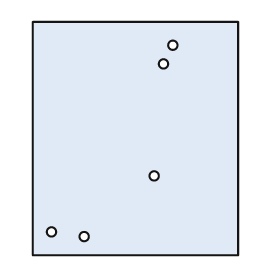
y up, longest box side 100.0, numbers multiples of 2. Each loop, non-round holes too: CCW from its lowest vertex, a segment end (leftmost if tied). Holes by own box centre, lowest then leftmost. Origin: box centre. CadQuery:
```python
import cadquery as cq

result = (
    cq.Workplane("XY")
    .moveTo(-44.0, -50.0)
    .lineTo(44.0, -50.0)
    .lineTo(44.0, 50.0)
    .lineTo(-44.0, 50.0)
    .close()
    .moveTo(-22.0, -42.0)
    .circle(2.0)
    .moveTo(-36.0, -40.0)
    .circle(2.0)
    .moveTo(8.0, -16.0)
    .circle(2.0)
    .moveTo(12.0, 32.0)
    .circle(2.0)
    .moveTo(16.0, 40.0)
    .circle(2.0)
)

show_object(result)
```